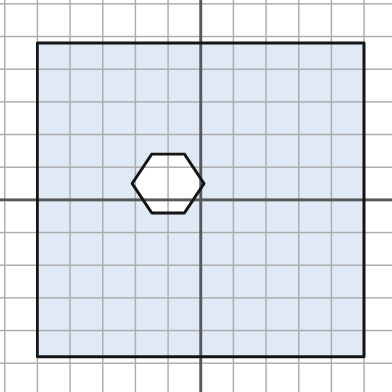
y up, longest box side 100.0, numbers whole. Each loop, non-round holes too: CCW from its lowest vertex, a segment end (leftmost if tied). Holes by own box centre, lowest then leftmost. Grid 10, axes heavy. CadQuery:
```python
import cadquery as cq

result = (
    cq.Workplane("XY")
    .moveTo(-50.0, -48.0)
    .lineTo(50.0, -48.0)
    .lineTo(50.0, 48.0)
    .lineTo(-50.0, 48.0)
    .close()
    .moveTo(-15.0, -4.0)
    .lineTo(-5.0, -4.0)
    .lineTo(1.0, 5.0)
    .lineTo(-5.0, 14.0)
    .lineTo(-15.0, 14.0)
    .lineTo(-21.0, 5.0)
    .close()
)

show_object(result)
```